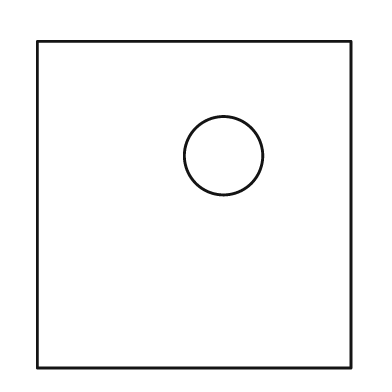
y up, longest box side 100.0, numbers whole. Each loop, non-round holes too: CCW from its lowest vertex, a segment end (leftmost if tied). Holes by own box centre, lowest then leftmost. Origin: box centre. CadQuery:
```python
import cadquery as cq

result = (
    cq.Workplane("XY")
    .moveTo(-48.0, -50.0)
    .lineTo(48.0, -50.0)
    .lineTo(48.0, 50.0)
    .lineTo(-48.0, 50.0)
    .close()
    .moveTo(9.0, 15.0)
    .circle(12.0)
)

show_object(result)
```